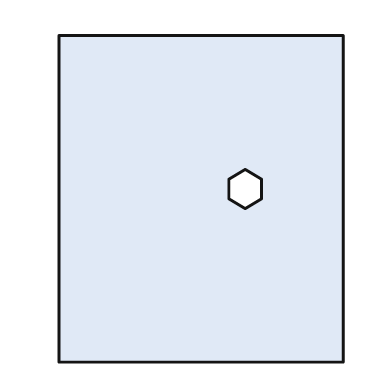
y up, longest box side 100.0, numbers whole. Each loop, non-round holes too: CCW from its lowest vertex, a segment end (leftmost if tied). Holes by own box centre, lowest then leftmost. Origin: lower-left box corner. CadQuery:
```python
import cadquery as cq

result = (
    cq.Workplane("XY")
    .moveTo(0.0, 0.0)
    .lineTo(87.0, 0.0)
    .lineTo(87.0, 100.0)
    .lineTo(0.0, 100.0)
    .close()
    .moveTo(57.0, 47.0)
    .lineTo(62.0, 50.0)
    .lineTo(62.0, 56.0)
    .lineTo(57.0, 59.0)
    .lineTo(52.0, 56.0)
    .lineTo(52.0, 50.0)
    .close()
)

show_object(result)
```